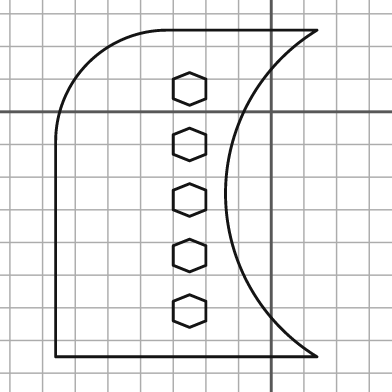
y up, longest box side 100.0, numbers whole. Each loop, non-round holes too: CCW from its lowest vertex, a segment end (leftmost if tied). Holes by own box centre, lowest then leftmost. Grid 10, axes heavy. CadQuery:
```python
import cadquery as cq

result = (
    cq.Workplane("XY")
    .moveTo(-66.0, -75.0)
    .lineTo(14.0, -75.0)
    .threePointArc((-14.0, -25.0), (14.0, 25.0))
    .lineTo(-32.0, 25.0)
    .threePointArc((-56.0, 15.0), (-66.0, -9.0))
    .close()
    .moveTo(-25.0, -66.0)
    .lineTo(-20.0, -64.0)
    .lineTo(-20.0, -58.0)
    .lineTo(-25.0, -56.0)
    .lineTo(-30.0, -58.0)
    .lineTo(-30.0, -64.0)
    .close()
    .moveTo(-25.0, -49.0)
    .lineTo(-20.0, -47.0)
    .lineTo(-20.0, -41.0)
    .lineTo(-25.0, -39.0)
    .lineTo(-30.0, -41.0)
    .lineTo(-30.0, -47.0)
    .close()
    .moveTo(-25.0, -32.0)
    .lineTo(-20.0, -30.0)
    .lineTo(-20.0, -24.0)
    .lineTo(-25.0, -22.0)
    .lineTo(-30.0, -24.0)
    .lineTo(-30.0, -30.0)
    .close()
    .moveTo(-25.0, -15.0)
    .lineTo(-20.0, -13.0)
    .lineTo(-20.0, -7.0)
    .lineTo(-25.0, -5.0)
    .lineTo(-30.0, -7.0)
    .lineTo(-30.0, -13.0)
    .close()
    .moveTo(-25.0, 2.0)
    .lineTo(-20.0, 4.0)
    .lineTo(-20.0, 10.0)
    .lineTo(-25.0, 12.0)
    .lineTo(-30.0, 10.0)
    .lineTo(-30.0, 4.0)
    .close()
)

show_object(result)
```